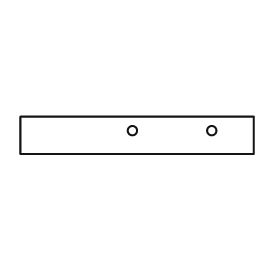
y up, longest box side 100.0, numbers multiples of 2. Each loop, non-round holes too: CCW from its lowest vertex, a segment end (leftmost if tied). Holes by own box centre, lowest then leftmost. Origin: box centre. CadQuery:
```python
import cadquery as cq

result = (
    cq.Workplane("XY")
    .moveTo(-50.0, -8.0)
    .lineTo(50.0, -8.0)
    .lineTo(50.0, 8.0)
    .lineTo(-50.0, 8.0)
    .close()
    .moveTo(-2.0, 2.0)
    .circle(2.0)
    .moveTo(32.0, 2.0)
    .circle(2.0)
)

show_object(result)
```